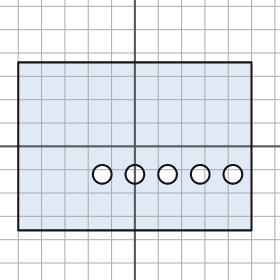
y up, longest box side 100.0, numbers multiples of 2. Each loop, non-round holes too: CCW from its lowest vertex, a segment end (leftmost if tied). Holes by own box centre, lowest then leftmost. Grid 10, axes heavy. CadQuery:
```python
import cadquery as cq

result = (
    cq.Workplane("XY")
    .moveTo(-50.0, -36.0)
    .lineTo(50.0, -36.0)
    .lineTo(50.0, 36.0)
    .lineTo(-50.0, 36.0)
    .close()
    .moveTo(-14.0, -12.0)
    .circle(4.0)
    .moveTo(0.0, -12.0)
    .circle(4.0)
    .moveTo(14.0, -12.0)
    .circle(4.0)
    .moveTo(28.0, -12.0)
    .circle(4.0)
    .moveTo(42.0, -12.0)
    .circle(4.0)
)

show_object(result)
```